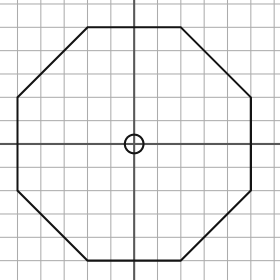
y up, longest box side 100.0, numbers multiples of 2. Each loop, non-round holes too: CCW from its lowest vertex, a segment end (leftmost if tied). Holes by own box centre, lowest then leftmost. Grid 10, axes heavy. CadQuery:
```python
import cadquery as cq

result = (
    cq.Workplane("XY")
    .moveTo(-20.0, -50.0)
    .lineTo(20.0, -50.0)
    .lineTo(50.0, -20.0)
    .lineTo(50.0, 20.0)
    .lineTo(20.0, 50.0)
    .lineTo(-20.0, 50.0)
    .lineTo(-50.0, 20.0)
    .lineTo(-50.0, -20.0)
    .close()
    .moveTo(0.0, 0.0)
    .circle(4.0)
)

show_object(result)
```